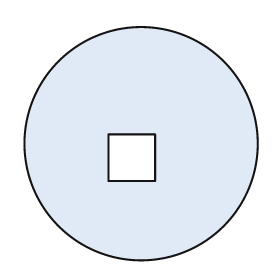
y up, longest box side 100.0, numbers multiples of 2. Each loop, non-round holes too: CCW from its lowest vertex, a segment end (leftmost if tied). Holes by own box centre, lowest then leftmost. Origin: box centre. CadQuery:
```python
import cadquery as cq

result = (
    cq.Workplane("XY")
    .moveTo(0.0, 0.0)
    .circle(50.0)
    .moveTo(-14.0, -16.0)
    .lineTo(6.0, -16.0)
    .lineTo(6.0, 4.0)
    .lineTo(-14.0, 4.0)
    .close()
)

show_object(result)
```